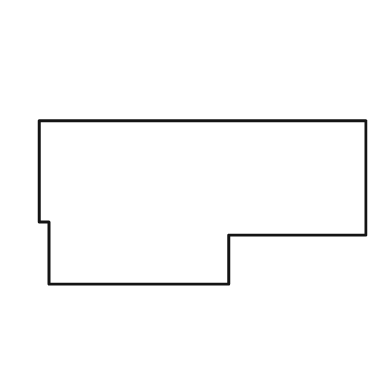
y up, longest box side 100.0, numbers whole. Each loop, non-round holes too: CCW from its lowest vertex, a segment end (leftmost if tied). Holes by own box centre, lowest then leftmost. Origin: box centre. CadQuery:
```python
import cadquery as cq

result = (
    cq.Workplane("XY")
    .moveTo(-47.0, -25.0)
    .lineTo(8.0, -25.0)
    .lineTo(8.0, -10.0)
    .lineTo(50.0, -10.0)
    .lineTo(50.0, 25.0)
    .lineTo(-50.0, 25.0)
    .lineTo(-50.0, -6.0)
    .lineTo(-47.0, -6.0)
    .close()
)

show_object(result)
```